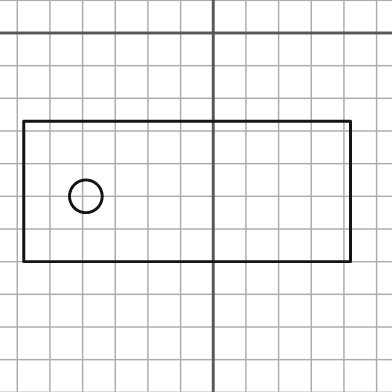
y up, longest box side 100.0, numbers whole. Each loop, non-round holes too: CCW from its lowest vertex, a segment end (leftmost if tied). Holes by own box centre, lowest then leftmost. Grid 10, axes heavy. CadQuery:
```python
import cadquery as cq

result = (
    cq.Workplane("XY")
    .moveTo(-58.0, -70.0)
    .lineTo(42.0, -70.0)
    .lineTo(42.0, -27.0)
    .lineTo(-58.0, -27.0)
    .close()
    .moveTo(-39.0, -50.0)
    .circle(5.0)
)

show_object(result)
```